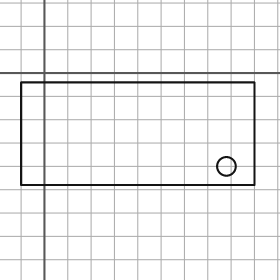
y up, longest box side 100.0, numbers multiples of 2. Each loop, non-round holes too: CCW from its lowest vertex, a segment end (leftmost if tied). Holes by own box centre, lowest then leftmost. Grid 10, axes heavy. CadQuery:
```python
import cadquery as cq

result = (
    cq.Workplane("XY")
    .moveTo(-10.0, -48.0)
    .lineTo(90.0, -48.0)
    .lineTo(90.0, -4.0)
    .lineTo(-10.0, -4.0)
    .close()
    .moveTo(78.0, -40.0)
    .circle(4.0)
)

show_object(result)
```